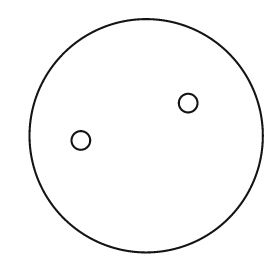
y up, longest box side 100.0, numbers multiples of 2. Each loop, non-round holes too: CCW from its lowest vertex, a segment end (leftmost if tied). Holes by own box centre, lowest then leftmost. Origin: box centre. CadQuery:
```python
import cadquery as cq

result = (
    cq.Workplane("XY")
    .moveTo(0.0, 0.0)
    .circle(50.0)
    .moveTo(-28.0, -2.0)
    .circle(4.0)
    .moveTo(18.0, 14.0)
    .circle(4.0)
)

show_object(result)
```